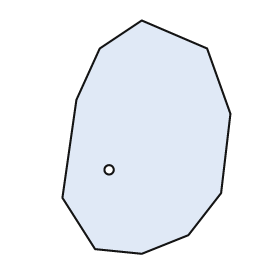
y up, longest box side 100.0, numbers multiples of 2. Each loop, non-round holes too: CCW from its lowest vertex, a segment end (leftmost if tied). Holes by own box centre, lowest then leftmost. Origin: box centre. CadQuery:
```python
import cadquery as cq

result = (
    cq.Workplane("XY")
    .moveTo(-2.0, -50.0)
    .lineTo(18.0, -42.0)
    .lineTo(32.0, -24.0)
    .lineTo(36.0, 10.0)
    .lineTo(26.0, 38.0)
    .lineTo(-2.0, 50.0)
    .lineTo(-20.0, 38.0)
    .lineTo(-30.0, 16.0)
    .lineTo(-36.0, -26.0)
    .lineTo(-22.0, -48.0)
    .close()
    .moveTo(-16.0, -14.0)
    .circle(2.0)
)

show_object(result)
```